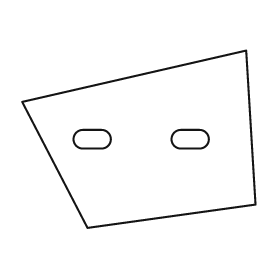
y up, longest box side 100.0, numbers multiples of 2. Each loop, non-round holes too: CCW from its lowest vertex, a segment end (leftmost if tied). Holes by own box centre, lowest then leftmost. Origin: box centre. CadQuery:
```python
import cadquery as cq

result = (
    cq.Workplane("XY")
    .moveTo(-22.0, -38.0)
    .lineTo(50.0, -28.0)
    .lineTo(46.0, 38.0)
    .lineTo(-50.0, 16.0)
    .close()
    .moveTo(-24.0, -4.0)
    .lineTo(-16.0, -4.0)
    .threePointArc((-12.0, 0.0), (-16.0, 4.0))
    .lineTo(-24.0, 4.0)
    .threePointArc((-28.0, 0.0), (-24.0, -4.0))
    .close()
    .moveTo(18.0, -4.0)
    .lineTo(26.0, -4.0)
    .threePointArc((30.0, 0.0), (26.0, 4.0))
    .lineTo(18.0, 4.0)
    .threePointArc((14.0, 0.0), (18.0, -4.0))
    .close()
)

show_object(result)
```